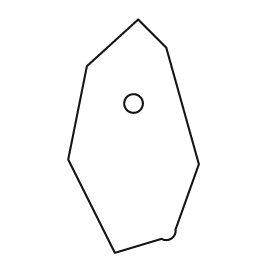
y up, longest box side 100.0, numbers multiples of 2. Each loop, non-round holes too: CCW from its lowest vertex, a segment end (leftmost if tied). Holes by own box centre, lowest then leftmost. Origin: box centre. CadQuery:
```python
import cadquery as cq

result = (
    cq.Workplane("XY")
    .moveTo(-8.0, -50.0)
    .lineTo(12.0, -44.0)
    .threePointArc((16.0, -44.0), (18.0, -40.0))
    .lineTo(28.0, -12.0)
    .lineTo(14.0, 38.0)
    .lineTo(2.0, 50.0)
    .lineTo(-20.0, 30.0)
    .lineTo(-28.0, -10.0)
    .close()
    .moveTo(0.0, 14.0)
    .circle(4.0)
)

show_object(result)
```